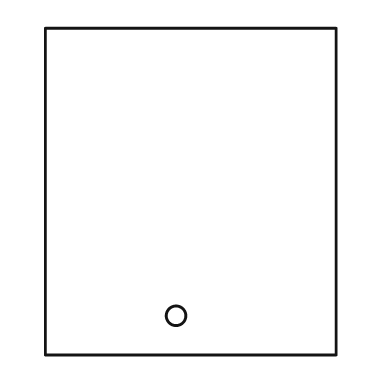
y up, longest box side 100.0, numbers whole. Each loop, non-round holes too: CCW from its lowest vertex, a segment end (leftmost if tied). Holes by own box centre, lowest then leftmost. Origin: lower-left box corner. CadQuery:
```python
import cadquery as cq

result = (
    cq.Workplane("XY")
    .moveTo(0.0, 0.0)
    .lineTo(89.0, 0.0)
    .lineTo(89.0, 100.0)
    .lineTo(0.0, 100.0)
    .close()
    .moveTo(40.0, 12.0)
    .circle(3.0)
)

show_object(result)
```